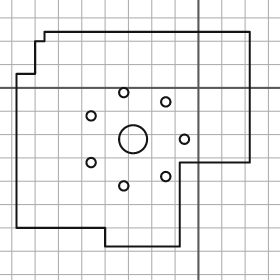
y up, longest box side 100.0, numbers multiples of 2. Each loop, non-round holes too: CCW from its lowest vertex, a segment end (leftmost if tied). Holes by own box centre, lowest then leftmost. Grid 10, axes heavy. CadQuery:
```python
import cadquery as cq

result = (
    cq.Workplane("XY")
    .moveTo(-40.0, -68.0)
    .lineTo(-8.0, -68.0)
    .lineTo(-8.0, -32.0)
    .lineTo(22.0, -32.0)
    .lineTo(22.0, 24.0)
    .lineTo(-66.0, 24.0)
    .lineTo(-66.0, 20.0)
    .lineTo(-70.0, 20.0)
    .lineTo(-70.0, 6.0)
    .lineTo(-78.0, 6.0)
    .lineTo(-78.0, -60.0)
    .lineTo(-40.0, -60.0)
    .close()
    .moveTo(-32.0, -42.0)
    .circle(2.0)
    .moveTo(-14.0, -38.0)
    .circle(2.0)
    .moveTo(-46.0, -32.0)
    .circle(2.0)
    .moveTo(-28.0, -22.0)
    .circle(6.0)
    .moveTo(-6.0, -22.0)
    .circle(2.0)
    .moveTo(-46.0, -12.0)
    .circle(2.0)
    .moveTo(-14.0, -6.0)
    .circle(2.0)
    .moveTo(-32.0, -2.0)
    .circle(2.0)
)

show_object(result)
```